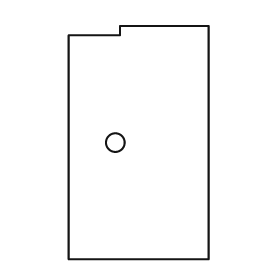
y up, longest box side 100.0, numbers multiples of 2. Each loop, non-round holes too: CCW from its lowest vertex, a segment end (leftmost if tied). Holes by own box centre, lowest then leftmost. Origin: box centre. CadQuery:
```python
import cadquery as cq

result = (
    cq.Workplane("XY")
    .moveTo(-30.0, -50.0)
    .lineTo(30.0, -50.0)
    .lineTo(30.0, 50.0)
    .lineTo(-8.0, 50.0)
    .lineTo(-8.0, 46.0)
    .lineTo(-30.0, 46.0)
    .close()
    .moveTo(-10.0, 0.0)
    .circle(4.0)
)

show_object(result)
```